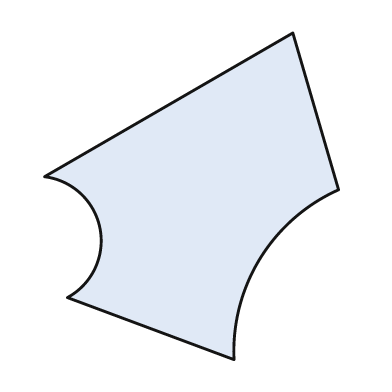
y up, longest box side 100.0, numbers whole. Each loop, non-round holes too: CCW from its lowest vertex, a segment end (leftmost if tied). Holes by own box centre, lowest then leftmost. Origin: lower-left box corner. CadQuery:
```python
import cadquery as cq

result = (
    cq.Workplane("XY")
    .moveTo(58.0, 0.0)
    .threePointArc((66.0, 31.0), (90.0, 52.0))
    .lineTo(76.0, 100.0)
    .lineTo(0.0, 56.0)
    .threePointArc((17.0, 40.0), (7.0, 19.0))
    .close()
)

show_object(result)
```